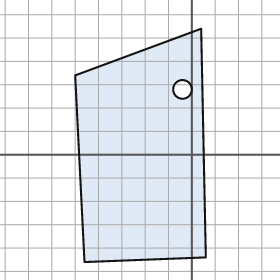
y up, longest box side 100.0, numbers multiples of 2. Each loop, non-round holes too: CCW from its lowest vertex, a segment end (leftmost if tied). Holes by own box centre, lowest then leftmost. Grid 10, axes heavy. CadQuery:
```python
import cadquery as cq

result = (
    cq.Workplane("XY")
    .moveTo(-46.0, -46.0)
    .lineTo(6.0, -44.0)
    .lineTo(4.0, 54.0)
    .lineTo(-50.0, 34.0)
    .close()
    .moveTo(-4.0, 28.0)
    .circle(4.0)
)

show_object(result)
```